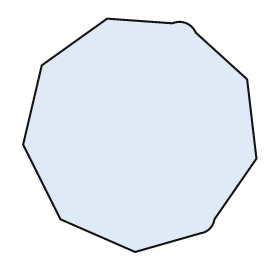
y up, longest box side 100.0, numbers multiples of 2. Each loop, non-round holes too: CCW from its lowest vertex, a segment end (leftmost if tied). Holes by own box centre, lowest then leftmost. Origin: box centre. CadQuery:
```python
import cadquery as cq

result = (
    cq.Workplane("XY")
    .moveTo(-2.0, -50.0)
    .lineTo(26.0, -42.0)
    .threePointArc((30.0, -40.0), (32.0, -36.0))
    .lineTo(50.0, -10.0)
    .lineTo(46.0, 24.0)
    .lineTo(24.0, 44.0)
    .threePointArc((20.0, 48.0), (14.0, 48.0))
    .lineTo(-14.0, 50.0)
    .lineTo(-42.0, 30.0)
    .lineTo(-50.0, -4.0)
    .lineTo(-34.0, -36.0)
    .close()
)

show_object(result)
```